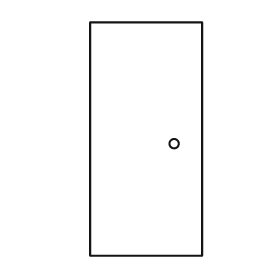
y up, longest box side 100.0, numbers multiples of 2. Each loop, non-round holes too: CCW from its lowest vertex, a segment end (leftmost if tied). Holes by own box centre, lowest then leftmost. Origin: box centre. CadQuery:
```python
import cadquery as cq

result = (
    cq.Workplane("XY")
    .moveTo(-24.0, -50.0)
    .lineTo(24.0, -50.0)
    .lineTo(24.0, 50.0)
    .lineTo(-24.0, 50.0)
    .close()
    .moveTo(12.0, -2.0)
    .circle(2.0)
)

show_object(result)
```